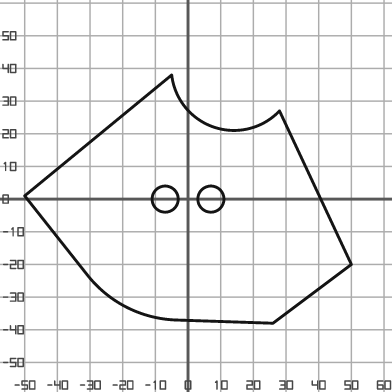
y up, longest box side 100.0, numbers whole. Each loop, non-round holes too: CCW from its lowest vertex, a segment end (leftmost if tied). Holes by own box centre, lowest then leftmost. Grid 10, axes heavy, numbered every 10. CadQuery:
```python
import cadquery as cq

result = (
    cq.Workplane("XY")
    .moveTo(26.0, -38.0)
    .lineTo(50.0, -20.0)
    .lineTo(28.0, 27.0)
    .threePointArc((8.0, 22.0), (-5.0, 38.0))
    .lineTo(-50.0, 1.0)
    .lineTo(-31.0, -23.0)
    .threePointArc((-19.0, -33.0), (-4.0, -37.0))
    .close()
    .moveTo(-7.0, 0.0)
    .circle(4.0)
    .moveTo(7.0, 0.0)
    .circle(4.0)
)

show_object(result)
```